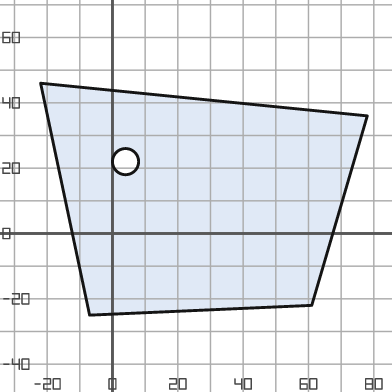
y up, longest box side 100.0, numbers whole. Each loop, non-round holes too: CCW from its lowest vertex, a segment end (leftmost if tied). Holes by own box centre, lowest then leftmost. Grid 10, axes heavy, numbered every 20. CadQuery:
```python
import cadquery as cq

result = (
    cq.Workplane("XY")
    .moveTo(-7.0, -25.0)
    .lineTo(61.0, -22.0)
    .lineTo(78.0, 36.0)
    .lineTo(-22.0, 46.0)
    .close()
    .moveTo(4.0, 22.0)
    .circle(4.0)
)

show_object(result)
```